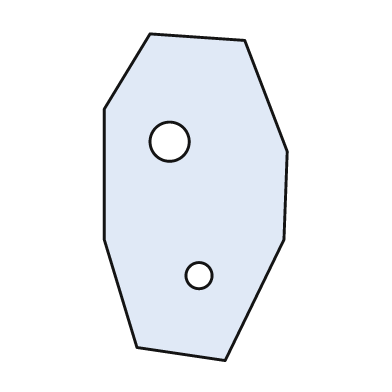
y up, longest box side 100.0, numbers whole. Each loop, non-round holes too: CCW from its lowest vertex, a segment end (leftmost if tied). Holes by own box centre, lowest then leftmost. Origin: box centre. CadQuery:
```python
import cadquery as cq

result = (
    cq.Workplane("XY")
    .moveTo(9.0, -50.0)
    .lineTo(27.0, -13.0)
    .lineTo(28.0, 14.0)
    .lineTo(15.0, 48.0)
    .lineTo(-14.0, 50.0)
    .lineTo(-28.0, 27.0)
    .lineTo(-28.0, -13.0)
    .lineTo(-18.0, -46.0)
    .close()
    .moveTo(1.0, -24.0)
    .circle(4.0)
    .moveTo(-8.0, 17.0)
    .circle(6.0)
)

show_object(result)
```